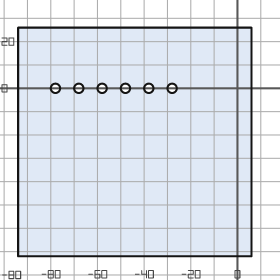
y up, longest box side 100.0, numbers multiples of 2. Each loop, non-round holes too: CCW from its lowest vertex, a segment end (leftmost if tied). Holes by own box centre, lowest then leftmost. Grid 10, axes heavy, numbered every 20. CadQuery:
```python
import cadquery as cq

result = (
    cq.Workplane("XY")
    .moveTo(-94.0, -72.0)
    .lineTo(6.0, -72.0)
    .lineTo(6.0, 26.0)
    .lineTo(-94.0, 26.0)
    .close()
    .moveTo(-78.0, 0.0)
    .circle(2.0)
    .moveTo(-68.0, 0.0)
    .circle(2.0)
    .moveTo(-58.0, 0.0)
    .circle(2.0)
    .moveTo(-48.0, 0.0)
    .circle(2.0)
    .moveTo(-38.0, 0.0)
    .circle(2.0)
    .moveTo(-28.0, 0.0)
    .circle(2.0)
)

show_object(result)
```